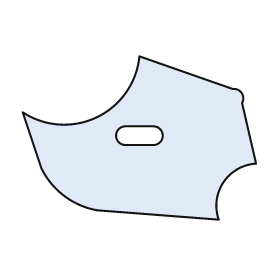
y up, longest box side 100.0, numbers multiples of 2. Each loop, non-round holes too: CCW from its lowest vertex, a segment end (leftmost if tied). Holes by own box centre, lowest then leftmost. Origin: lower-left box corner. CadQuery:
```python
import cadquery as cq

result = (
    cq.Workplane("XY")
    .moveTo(84.0, 0.0)
    .threePointArc((86.0, 16.0), (100.0, 24.0))
    .lineTo(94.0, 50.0)
    .threePointArc((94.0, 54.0), (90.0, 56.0))
    .lineTo(50.0, 70.0)
    .threePointArc((32.0, 44.0), (0.0, 46.0))
    .lineTo(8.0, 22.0)
    .threePointArc((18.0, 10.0), (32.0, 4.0))
    .close()
    .moveTo(44.0, 32.0)
    .lineTo(56.0, 32.0)
    .threePointArc((60.0, 36.0), (56.0, 40.0))
    .lineTo(44.0, 40.0)
    .threePointArc((40.0, 36.0), (44.0, 32.0))
    .close()
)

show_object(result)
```